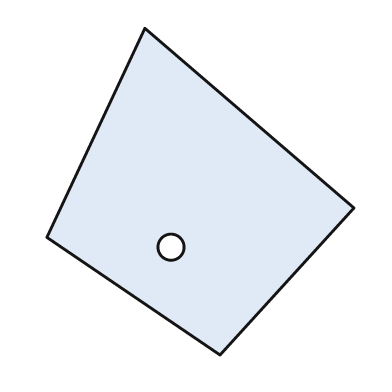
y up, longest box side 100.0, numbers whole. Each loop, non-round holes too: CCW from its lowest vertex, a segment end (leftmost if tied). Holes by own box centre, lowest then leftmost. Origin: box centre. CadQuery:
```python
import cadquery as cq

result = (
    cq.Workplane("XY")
    .moveTo(6.0, -50.0)
    .lineTo(47.0, -5.0)
    .lineTo(-17.0, 50.0)
    .lineTo(-47.0, -14.0)
    .close()
    .moveTo(-9.0, -17.0)
    .circle(4.0)
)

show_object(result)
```